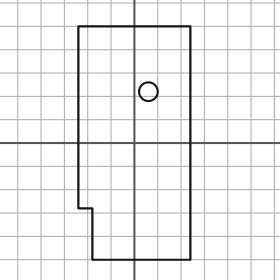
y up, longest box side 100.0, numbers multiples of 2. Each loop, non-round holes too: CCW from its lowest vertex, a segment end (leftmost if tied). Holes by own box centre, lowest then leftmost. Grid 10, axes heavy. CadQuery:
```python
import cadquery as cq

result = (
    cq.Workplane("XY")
    .moveTo(-18.0, -50.0)
    .lineTo(24.0, -50.0)
    .lineTo(24.0, 50.0)
    .lineTo(-24.0, 50.0)
    .lineTo(-24.0, -28.0)
    .lineTo(-18.0, -28.0)
    .close()
    .moveTo(6.0, 22.0)
    .circle(4.0)
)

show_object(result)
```